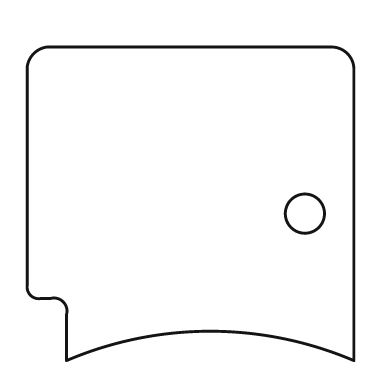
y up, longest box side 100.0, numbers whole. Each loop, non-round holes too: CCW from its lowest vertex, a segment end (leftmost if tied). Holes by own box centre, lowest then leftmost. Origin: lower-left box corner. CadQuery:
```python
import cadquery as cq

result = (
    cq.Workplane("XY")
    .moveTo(12.0, 0.0)
    .threePointArc((56.0, 9.0), (100.0, 0.0))
    .lineTo(100.0, 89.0)
    .threePointArc((98.0, 94.0), (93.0, 96.0))
    .lineTo(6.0, 96.0)
    .threePointArc((2.0, 94.0), (0.0, 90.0))
    .lineTo(0.0, 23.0)
    .threePointArc((1.0, 20.0), (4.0, 19.0))
    .lineTo(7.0, 19.0)
    .threePointArc((11.0, 18.0), (12.0, 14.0))
    .close()
    .moveTo(85.0, 45.0)
    .circle(6.0)
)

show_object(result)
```